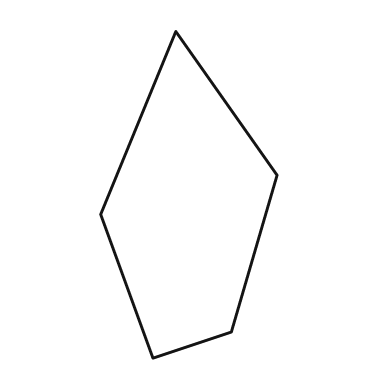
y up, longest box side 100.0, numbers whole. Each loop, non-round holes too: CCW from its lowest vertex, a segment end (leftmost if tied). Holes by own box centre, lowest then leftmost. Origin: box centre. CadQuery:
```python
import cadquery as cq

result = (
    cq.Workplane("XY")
    .moveTo(-11.0, -50.0)
    .lineTo(13.0, -42.0)
    .lineTo(27.0, 6.0)
    .lineTo(-4.0, 50.0)
    .lineTo(-27.0, -6.0)
    .close()
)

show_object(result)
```